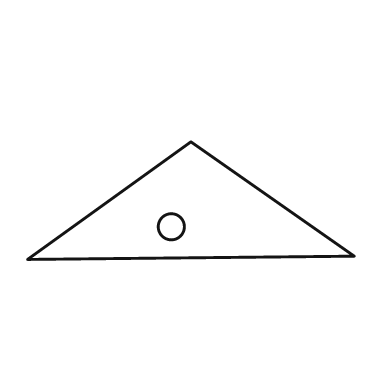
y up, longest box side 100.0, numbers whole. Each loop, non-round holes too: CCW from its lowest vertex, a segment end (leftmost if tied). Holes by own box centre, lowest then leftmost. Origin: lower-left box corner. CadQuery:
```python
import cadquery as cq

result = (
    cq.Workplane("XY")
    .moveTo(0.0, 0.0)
    .lineTo(100.0, 1.0)
    .lineTo(50.0, 36.0)
    .close()
    .moveTo(44.0, 10.0)
    .circle(4.0)
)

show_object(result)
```